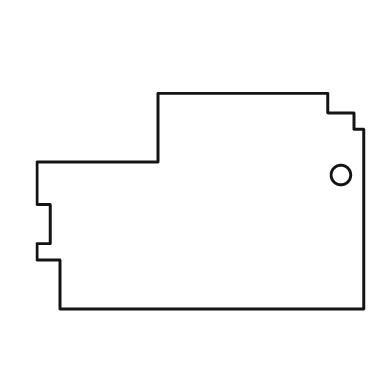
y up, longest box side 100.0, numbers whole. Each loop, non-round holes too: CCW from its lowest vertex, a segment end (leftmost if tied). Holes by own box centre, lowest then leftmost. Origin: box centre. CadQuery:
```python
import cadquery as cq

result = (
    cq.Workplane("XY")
    .moveTo(-43.0, -33.0)
    .lineTo(50.0, -33.0)
    .lineTo(50.0, 22.0)
    .lineTo(47.0, 22.0)
    .lineTo(47.0, 27.0)
    .lineTo(39.0, 27.0)
    .lineTo(39.0, 33.0)
    .lineTo(-13.0, 33.0)
    .lineTo(-13.0, 12.0)
    .lineTo(-50.0, 12.0)
    .lineTo(-50.0, -1.0)
    .lineTo(-46.0, -1.0)
    .lineTo(-46.0, -13.0)
    .lineTo(-50.0, -13.0)
    .lineTo(-50.0, -18.0)
    .lineTo(-43.0, -18.0)
    .close()
    .moveTo(43.0, 8.0)
    .circle(3.0)
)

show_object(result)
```